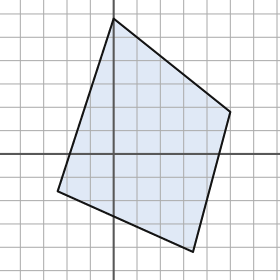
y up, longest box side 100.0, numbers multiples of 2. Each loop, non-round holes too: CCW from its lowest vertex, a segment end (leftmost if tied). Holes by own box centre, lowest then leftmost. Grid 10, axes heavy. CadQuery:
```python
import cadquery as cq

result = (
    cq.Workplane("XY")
    .moveTo(34.0, -42.0)
    .lineTo(50.0, 18.0)
    .lineTo(0.0, 58.0)
    .lineTo(-24.0, -16.0)
    .close()
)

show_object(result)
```